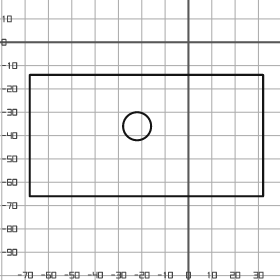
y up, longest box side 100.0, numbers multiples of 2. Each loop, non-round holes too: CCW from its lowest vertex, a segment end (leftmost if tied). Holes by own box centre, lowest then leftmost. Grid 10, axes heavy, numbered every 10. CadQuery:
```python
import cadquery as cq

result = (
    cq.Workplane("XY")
    .moveTo(-68.0, -66.0)
    .lineTo(32.0, -66.0)
    .lineTo(32.0, -14.0)
    .lineTo(-68.0, -14.0)
    .close()
    .moveTo(-22.0, -36.0)
    .circle(6.0)
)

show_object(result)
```